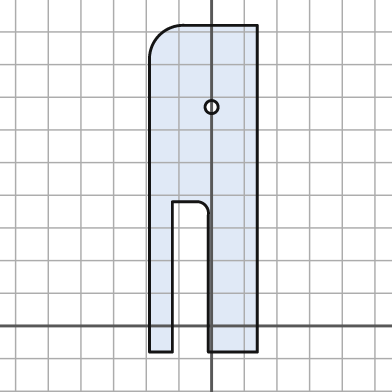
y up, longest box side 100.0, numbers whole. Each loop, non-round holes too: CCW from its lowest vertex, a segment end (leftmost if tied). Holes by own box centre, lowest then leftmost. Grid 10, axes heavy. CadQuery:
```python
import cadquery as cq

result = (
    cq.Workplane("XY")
    .moveTo(-19.0, -8.0)
    .lineTo(-12.0, -8.0)
    .lineTo(-12.0, 38.0)
    .lineTo(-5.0, 38.0)
    .threePointArc((-2.0, 37.0), (-1.0, 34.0))
    .lineTo(-1.0, -8.0)
    .lineTo(14.0, -8.0)
    .lineTo(14.0, 92.0)
    .lineTo(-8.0, 92.0)
    .threePointArc((-16.0, 89.0), (-19.0, 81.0))
    .close()
    .moveTo(0.0, 67.0)
    .circle(2.0)
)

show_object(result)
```